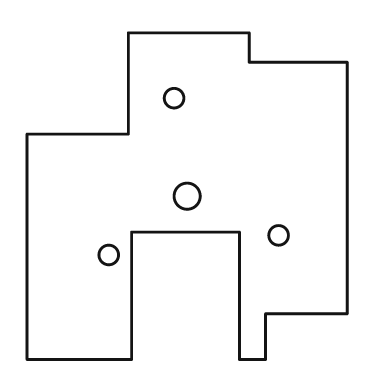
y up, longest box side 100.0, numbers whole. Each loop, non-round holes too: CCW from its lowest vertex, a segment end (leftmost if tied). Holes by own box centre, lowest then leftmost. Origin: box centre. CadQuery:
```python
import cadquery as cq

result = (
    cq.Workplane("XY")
    .moveTo(-49.0, -50.0)
    .lineTo(-17.0, -50.0)
    .lineTo(-17.0, -11.0)
    .lineTo(16.0, -11.0)
    .lineTo(16.0, -50.0)
    .lineTo(24.0, -50.0)
    .lineTo(24.0, -36.0)
    .lineTo(49.0, -36.0)
    .lineTo(49.0, 41.0)
    .lineTo(19.0, 41.0)
    .lineTo(19.0, 50.0)
    .lineTo(-18.0, 50.0)
    .lineTo(-18.0, 19.0)
    .lineTo(-49.0, 19.0)
    .close()
    .moveTo(-24.0, -18.0)
    .circle(3.0)
    .moveTo(28.0, -12.0)
    .circle(3.0)
    .moveTo(0.0, 0.0)
    .circle(4.0)
    .moveTo(-4.0, 30.0)
    .circle(3.0)
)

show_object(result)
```